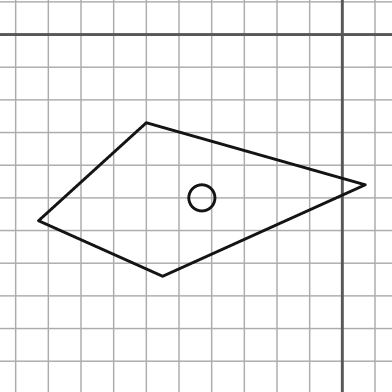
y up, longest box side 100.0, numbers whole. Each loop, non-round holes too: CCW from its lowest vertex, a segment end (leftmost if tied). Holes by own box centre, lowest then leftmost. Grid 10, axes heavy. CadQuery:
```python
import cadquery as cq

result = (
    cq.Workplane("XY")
    .moveTo(-55.0, -74.0)
    .lineTo(7.0, -46.0)
    .lineTo(-60.0, -27.0)
    .lineTo(-93.0, -57.0)
    .close()
    .moveTo(-43.0, -50.0)
    .circle(4.0)
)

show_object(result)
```